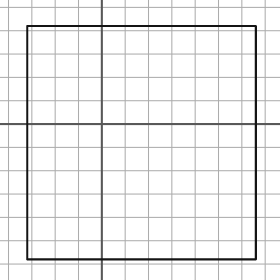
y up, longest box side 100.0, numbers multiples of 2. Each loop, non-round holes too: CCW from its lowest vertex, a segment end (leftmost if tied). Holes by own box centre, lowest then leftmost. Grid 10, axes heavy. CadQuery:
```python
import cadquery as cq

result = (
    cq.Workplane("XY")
    .moveTo(-32.0, -58.0)
    .lineTo(66.0, -58.0)
    .lineTo(66.0, 42.0)
    .lineTo(-32.0, 42.0)
    .close()
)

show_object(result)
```